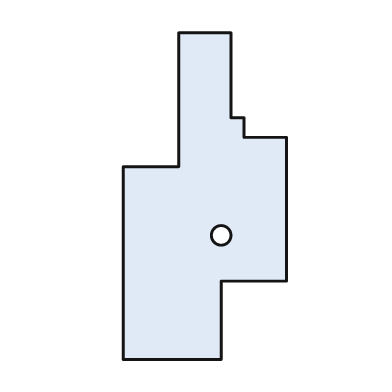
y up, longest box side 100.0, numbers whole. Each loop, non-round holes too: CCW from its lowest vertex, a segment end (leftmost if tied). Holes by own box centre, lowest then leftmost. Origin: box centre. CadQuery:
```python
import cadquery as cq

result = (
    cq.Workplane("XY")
    .moveTo(-25.0, -50.0)
    .lineTo(5.0, -50.0)
    .lineTo(5.0, -26.0)
    .lineTo(25.0, -26.0)
    .lineTo(25.0, 18.0)
    .lineTo(12.0, 18.0)
    .lineTo(12.0, 24.0)
    .lineTo(8.0, 24.0)
    .lineTo(8.0, 50.0)
    .lineTo(-8.0, 50.0)
    .lineTo(-8.0, 9.0)
    .lineTo(-25.0, 9.0)
    .close()
    .moveTo(5.0, -12.0)
    .circle(3.0)
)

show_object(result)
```